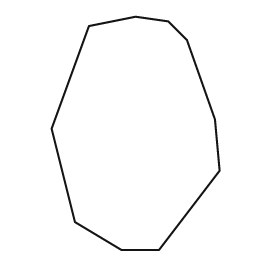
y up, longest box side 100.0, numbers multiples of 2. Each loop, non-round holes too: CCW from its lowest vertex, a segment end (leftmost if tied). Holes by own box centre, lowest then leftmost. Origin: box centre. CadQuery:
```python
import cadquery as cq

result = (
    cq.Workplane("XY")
    .moveTo(-6.0, -50.0)
    .lineTo(10.0, -50.0)
    .lineTo(36.0, -16.0)
    .lineTo(34.0, 6.0)
    .lineTo(22.0, 40.0)
    .lineTo(14.0, 48.0)
    .lineTo(0.0, 50.0)
    .lineTo(-20.0, 46.0)
    .lineTo(-36.0, 2.0)
    .lineTo(-26.0, -38.0)
    .close()
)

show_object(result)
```